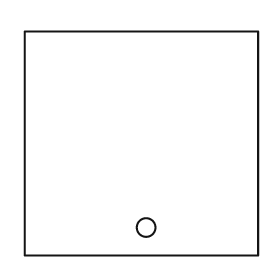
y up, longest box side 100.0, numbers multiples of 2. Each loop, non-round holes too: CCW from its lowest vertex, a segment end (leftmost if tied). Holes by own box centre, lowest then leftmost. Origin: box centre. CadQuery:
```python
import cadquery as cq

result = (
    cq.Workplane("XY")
    .moveTo(-50.0, -48.0)
    .lineTo(50.0, -48.0)
    .lineTo(50.0, 48.0)
    .lineTo(-50.0, 48.0)
    .close()
    .moveTo(2.0, -36.0)
    .circle(4.0)
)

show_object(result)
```